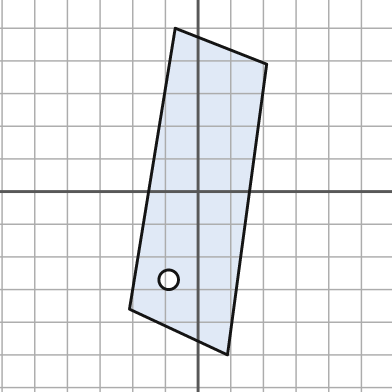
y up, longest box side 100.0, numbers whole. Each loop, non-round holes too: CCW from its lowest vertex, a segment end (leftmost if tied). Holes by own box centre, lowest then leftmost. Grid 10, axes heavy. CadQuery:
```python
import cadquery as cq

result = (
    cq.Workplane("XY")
    .moveTo(9.0, -50.0)
    .lineTo(21.0, 39.0)
    .lineTo(-7.0, 50.0)
    .lineTo(-21.0, -36.0)
    .close()
    .moveTo(-9.0, -27.0)
    .circle(3.0)
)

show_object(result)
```